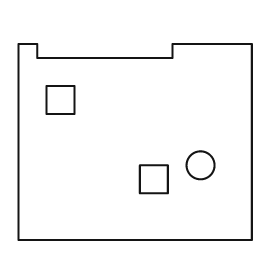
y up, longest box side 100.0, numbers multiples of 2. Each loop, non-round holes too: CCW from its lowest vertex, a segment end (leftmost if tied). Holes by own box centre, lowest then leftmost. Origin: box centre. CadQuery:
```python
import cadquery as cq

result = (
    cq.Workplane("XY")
    .moveTo(-50.0, -42.0)
    .lineTo(50.0, -42.0)
    .lineTo(50.0, 42.0)
    .lineTo(16.0, 42.0)
    .lineTo(16.0, 36.0)
    .lineTo(-42.0, 36.0)
    .lineTo(-42.0, 42.0)
    .lineTo(-50.0, 42.0)
    .close()
    .moveTo(2.0, -22.0)
    .lineTo(14.0, -22.0)
    .lineTo(14.0, -10.0)
    .lineTo(2.0, -10.0)
    .close()
    .moveTo(28.0, -10.0)
    .circle(6.0)
    .moveTo(-38.0, 12.0)
    .lineTo(-26.0, 12.0)
    .lineTo(-26.0, 24.0)
    .lineTo(-38.0, 24.0)
    .close()
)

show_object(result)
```